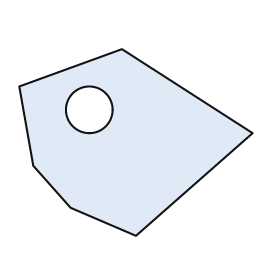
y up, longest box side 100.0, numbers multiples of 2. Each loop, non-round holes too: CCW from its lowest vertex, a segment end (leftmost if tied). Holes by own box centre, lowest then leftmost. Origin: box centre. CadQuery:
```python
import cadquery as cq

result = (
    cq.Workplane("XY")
    .moveTo(0.0, -40.0)
    .lineTo(50.0, 4.0)
    .lineTo(-6.0, 40.0)
    .lineTo(-50.0, 24.0)
    .lineTo(-44.0, -10.0)
    .lineTo(-28.0, -28.0)
    .close()
    .moveTo(-20.0, 14.0)
    .circle(10.0)
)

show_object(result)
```